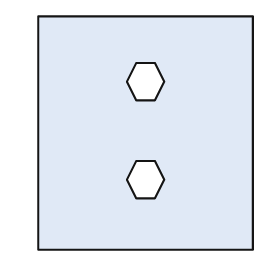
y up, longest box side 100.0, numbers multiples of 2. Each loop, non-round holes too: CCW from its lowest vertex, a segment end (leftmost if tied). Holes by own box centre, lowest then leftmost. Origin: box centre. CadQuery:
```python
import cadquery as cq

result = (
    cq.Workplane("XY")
    .moveTo(-46.0, -50.0)
    .lineTo(46.0, -50.0)
    .lineTo(46.0, 50.0)
    .lineTo(-46.0, 50.0)
    .close()
    .moveTo(-4.0, -28.0)
    .lineTo(4.0, -28.0)
    .lineTo(8.0, -20.0)
    .lineTo(4.0, -12.0)
    .lineTo(-4.0, -12.0)
    .lineTo(-8.0, -20.0)
    .close()
    .moveTo(-4.0, 14.0)
    .lineTo(4.0, 14.0)
    .lineTo(8.0, 22.0)
    .lineTo(4.0, 30.0)
    .lineTo(-4.0, 30.0)
    .lineTo(-8.0, 22.0)
    .close()
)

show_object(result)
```